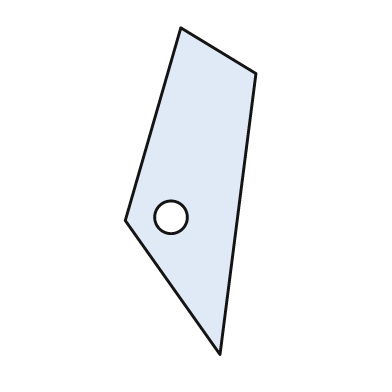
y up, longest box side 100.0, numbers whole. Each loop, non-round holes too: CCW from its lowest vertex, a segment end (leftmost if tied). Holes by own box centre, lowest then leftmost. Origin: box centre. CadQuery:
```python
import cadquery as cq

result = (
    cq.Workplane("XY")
    .moveTo(9.0, -50.0)
    .lineTo(20.0, 36.0)
    .lineTo(-3.0, 50.0)
    .lineTo(-20.0, -9.0)
    .close()
    .moveTo(-6.0, -8.0)
    .circle(5.0)
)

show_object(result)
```